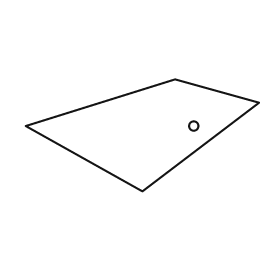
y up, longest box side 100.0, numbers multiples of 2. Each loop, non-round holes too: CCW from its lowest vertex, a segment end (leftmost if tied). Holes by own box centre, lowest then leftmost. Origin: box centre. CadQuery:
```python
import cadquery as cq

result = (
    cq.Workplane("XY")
    .moveTo(0.0, -24.0)
    .lineTo(50.0, 14.0)
    .lineTo(14.0, 24.0)
    .lineTo(-50.0, 4.0)
    .close()
    .moveTo(22.0, 4.0)
    .circle(2.0)
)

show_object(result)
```